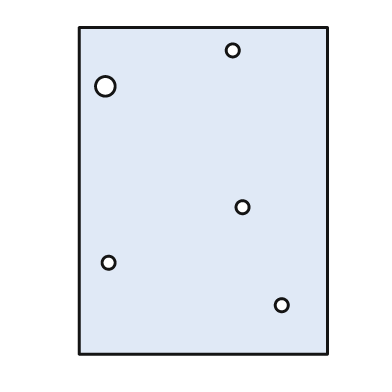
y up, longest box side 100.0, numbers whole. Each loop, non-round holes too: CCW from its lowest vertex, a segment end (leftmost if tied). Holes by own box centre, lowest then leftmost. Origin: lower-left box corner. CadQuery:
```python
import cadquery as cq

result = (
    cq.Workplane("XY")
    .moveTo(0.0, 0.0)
    .lineTo(76.0, 0.0)
    .lineTo(76.0, 100.0)
    .lineTo(0.0, 100.0)
    .close()
    .moveTo(62.0, 15.0)
    .circle(2.0)
    .moveTo(9.0, 28.0)
    .circle(2.0)
    .moveTo(50.0, 45.0)
    .circle(2.0)
    .moveTo(8.0, 82.0)
    .circle(3.0)
    .moveTo(47.0, 93.0)
    .circle(2.0)
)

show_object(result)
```